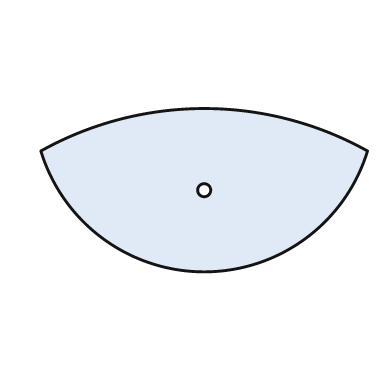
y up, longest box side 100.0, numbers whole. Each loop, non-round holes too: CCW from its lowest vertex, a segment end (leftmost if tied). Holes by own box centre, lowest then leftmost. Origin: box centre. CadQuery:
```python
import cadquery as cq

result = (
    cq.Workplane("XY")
    .moveTo(-50.0, 12.0)
    .threePointArc((0.0, -25.0), (50.0, 12.0))
    .threePointArc((0.0, 25.0), (-50.0, 12.0))
    .close()
    .moveTo(0.0, 0.0)
    .circle(2.0)
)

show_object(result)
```